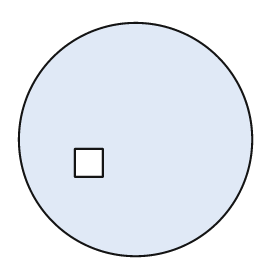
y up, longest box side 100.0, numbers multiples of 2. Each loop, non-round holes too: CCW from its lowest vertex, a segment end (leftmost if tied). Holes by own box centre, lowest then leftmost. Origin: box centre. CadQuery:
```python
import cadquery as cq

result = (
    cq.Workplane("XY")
    .moveTo(0.0, 0.0)
    .circle(50.0)
    .moveTo(-26.0, -16.0)
    .lineTo(-14.0, -16.0)
    .lineTo(-14.0, -4.0)
    .lineTo(-26.0, -4.0)
    .close()
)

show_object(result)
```